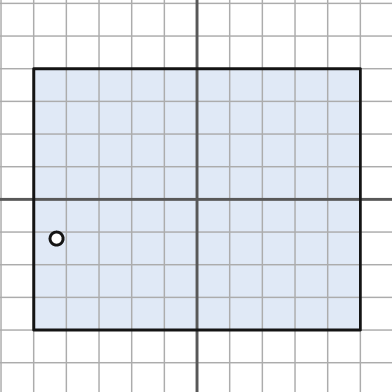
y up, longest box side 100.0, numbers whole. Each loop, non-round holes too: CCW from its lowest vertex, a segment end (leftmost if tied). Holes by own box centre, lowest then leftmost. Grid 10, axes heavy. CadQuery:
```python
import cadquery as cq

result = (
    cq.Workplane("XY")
    .moveTo(-50.0, -40.0)
    .lineTo(50.0, -40.0)
    .lineTo(50.0, 40.0)
    .lineTo(-50.0, 40.0)
    .close()
    .moveTo(-43.0, -12.0)
    .circle(2.0)
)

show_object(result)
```